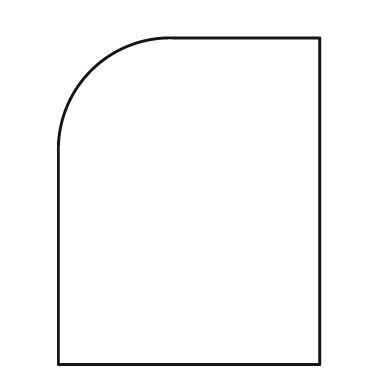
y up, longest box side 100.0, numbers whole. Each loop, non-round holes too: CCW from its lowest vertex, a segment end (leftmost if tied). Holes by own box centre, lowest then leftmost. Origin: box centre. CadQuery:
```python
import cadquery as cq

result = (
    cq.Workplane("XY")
    .moveTo(-40.0, -50.0)
    .lineTo(40.0, -50.0)
    .lineTo(40.0, 50.0)
    .lineTo(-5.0, 50.0)
    .threePointArc((-30.0, 40.0), (-40.0, 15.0))
    .close()
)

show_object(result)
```